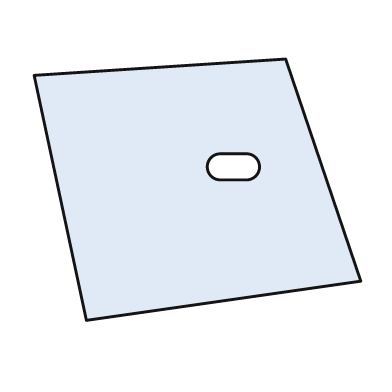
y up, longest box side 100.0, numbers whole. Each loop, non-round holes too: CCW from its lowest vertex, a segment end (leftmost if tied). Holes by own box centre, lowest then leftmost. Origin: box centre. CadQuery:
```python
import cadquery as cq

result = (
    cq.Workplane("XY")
    .moveTo(-34.0, -40.0)
    .lineTo(50.0, -28.0)
    .lineTo(27.0, 40.0)
    .lineTo(-50.0, 35.0)
    .close()
    .moveTo(7.0, 3.0)
    .lineTo(15.0, 3.0)
    .threePointArc((19.0, 7.0), (15.0, 11.0))
    .lineTo(7.0, 11.0)
    .threePointArc((3.0, 7.0), (7.0, 3.0))
    .close()
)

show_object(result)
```